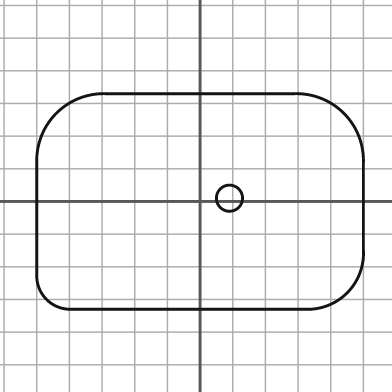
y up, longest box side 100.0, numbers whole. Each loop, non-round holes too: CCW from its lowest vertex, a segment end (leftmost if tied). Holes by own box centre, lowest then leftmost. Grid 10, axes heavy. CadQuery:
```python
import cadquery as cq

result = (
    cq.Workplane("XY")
    .moveTo(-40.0, -33.0)
    .lineTo(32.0, -33.0)
    .threePointArc((45.0, -28.0), (50.0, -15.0))
    .lineTo(50.0, 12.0)
    .threePointArc((44.0, 27.0), (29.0, 33.0))
    .lineTo(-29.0, 33.0)
    .threePointArc((-44.0, 27.0), (-50.0, 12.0))
    .lineTo(-50.0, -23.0)
    .threePointArc((-47.0, -30.0), (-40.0, -33.0))
    .close()
    .moveTo(9.0, 1.0)
    .circle(4.0)
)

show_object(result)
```